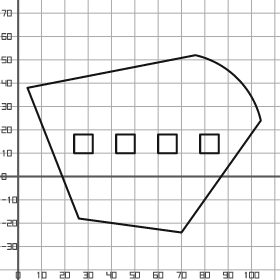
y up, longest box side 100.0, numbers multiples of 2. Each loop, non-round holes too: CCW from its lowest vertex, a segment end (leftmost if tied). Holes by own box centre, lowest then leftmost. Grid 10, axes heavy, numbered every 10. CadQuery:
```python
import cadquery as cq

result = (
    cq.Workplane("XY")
    .moveTo(70.0, -24.0)
    .lineTo(104.0, 24.0)
    .threePointArc((94.0, 42.0), (76.0, 52.0))
    .lineTo(4.0, 38.0)
    .lineTo(26.0, -18.0)
    .close()
    .moveTo(24.0, 10.0)
    .lineTo(32.0, 10.0)
    .lineTo(32.0, 18.0)
    .lineTo(24.0, 18.0)
    .close()
    .moveTo(42.0, 10.0)
    .lineTo(50.0, 10.0)
    .lineTo(50.0, 18.0)
    .lineTo(42.0, 18.0)
    .close()
    .moveTo(60.0, 10.0)
    .lineTo(68.0, 10.0)
    .lineTo(68.0, 18.0)
    .lineTo(60.0, 18.0)
    .close()
    .moveTo(78.0, 10.0)
    .lineTo(86.0, 10.0)
    .lineTo(86.0, 18.0)
    .lineTo(78.0, 18.0)
    .close()
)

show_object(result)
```